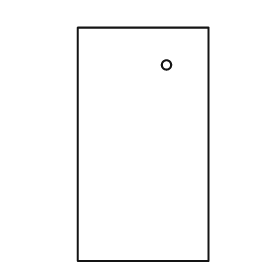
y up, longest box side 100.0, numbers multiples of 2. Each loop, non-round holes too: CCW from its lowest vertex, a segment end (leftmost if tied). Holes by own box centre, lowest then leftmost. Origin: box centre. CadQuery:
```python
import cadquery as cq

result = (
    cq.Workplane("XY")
    .moveTo(-28.0, -50.0)
    .lineTo(28.0, -50.0)
    .lineTo(28.0, 50.0)
    .lineTo(-28.0, 50.0)
    .close()
    .moveTo(10.0, 34.0)
    .circle(2.0)
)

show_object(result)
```